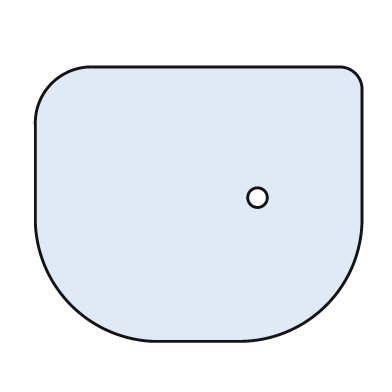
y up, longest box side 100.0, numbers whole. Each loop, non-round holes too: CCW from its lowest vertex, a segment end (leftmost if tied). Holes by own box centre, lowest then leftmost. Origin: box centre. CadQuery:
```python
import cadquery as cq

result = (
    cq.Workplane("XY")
    .moveTo(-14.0, -42.0)
    .lineTo(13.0, -42.0)
    .threePointArc((39.0, -31.0), (50.0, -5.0))
    .lineTo(50.0, 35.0)
    .threePointArc((48.0, 40.0), (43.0, 42.0))
    .lineTo(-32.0, 42.0)
    .threePointArc((-45.0, 37.0), (-50.0, 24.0))
    .lineTo(-50.0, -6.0)
    .threePointArc((-39.0, -31.0), (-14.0, -42.0))
    .close()
    .moveTo(18.0, 2.0)
    .circle(3.0)
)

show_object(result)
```